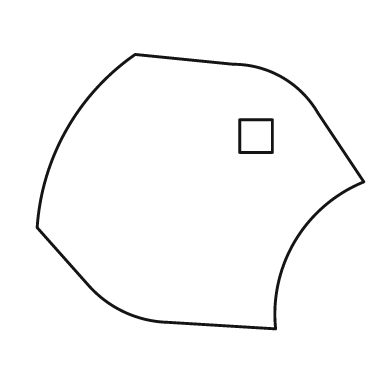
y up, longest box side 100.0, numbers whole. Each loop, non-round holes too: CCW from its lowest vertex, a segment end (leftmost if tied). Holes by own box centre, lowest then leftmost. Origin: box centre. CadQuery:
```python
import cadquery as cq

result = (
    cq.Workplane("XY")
    .moveTo(23.0, -42.0)
    .threePointArc((29.0, -15.0), (50.0, 3.0))
    .lineTo(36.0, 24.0)
    .threePointArc((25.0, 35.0), (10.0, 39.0))
    .lineTo(-20.0, 42.0)
    .threePointArc((-41.0, 19.0), (-50.0, -11.0))
    .lineTo(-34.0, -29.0)
    .threePointArc((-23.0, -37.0), (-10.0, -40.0))
    .close()
    .moveTo(12.0, 12.0)
    .lineTo(22.0, 12.0)
    .lineTo(22.0, 22.0)
    .lineTo(12.0, 22.0)
    .close()
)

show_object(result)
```